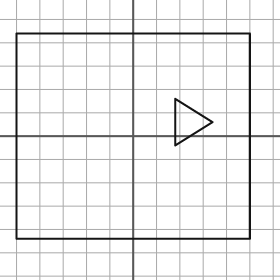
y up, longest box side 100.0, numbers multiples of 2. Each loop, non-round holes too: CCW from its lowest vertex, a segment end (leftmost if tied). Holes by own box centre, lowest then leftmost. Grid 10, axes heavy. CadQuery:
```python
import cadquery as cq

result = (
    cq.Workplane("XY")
    .moveTo(-50.0, -44.0)
    .lineTo(50.0, -44.0)
    .lineTo(50.0, 44.0)
    .lineTo(-50.0, 44.0)
    .close()
    .moveTo(18.0, -4.0)
    .lineTo(34.0, 6.0)
    .lineTo(18.0, 16.0)
    .close()
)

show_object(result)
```